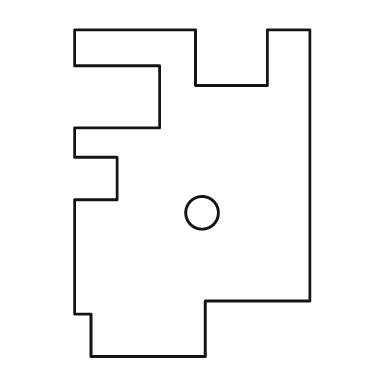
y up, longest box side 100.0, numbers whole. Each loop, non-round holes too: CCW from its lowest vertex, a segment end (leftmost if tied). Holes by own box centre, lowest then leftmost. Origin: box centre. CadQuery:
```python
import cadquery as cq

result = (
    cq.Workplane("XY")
    .moveTo(-31.0, -50.0)
    .lineTo(4.0, -50.0)
    .lineTo(4.0, -33.0)
    .lineTo(36.0, -33.0)
    .lineTo(36.0, 50.0)
    .lineTo(23.0, 50.0)
    .lineTo(23.0, 33.0)
    .lineTo(1.0, 33.0)
    .lineTo(1.0, 50.0)
    .lineTo(-36.0, 50.0)
    .lineTo(-36.0, 39.0)
    .lineTo(-10.0, 39.0)
    .lineTo(-10.0, 20.0)
    .lineTo(-36.0, 20.0)
    .lineTo(-36.0, 11.0)
    .lineTo(-23.0, 11.0)
    .lineTo(-23.0, -2.0)
    .lineTo(-36.0, -2.0)
    .lineTo(-36.0, -37.0)
    .lineTo(-31.0, -37.0)
    .close()
    .moveTo(3.0, -6.0)
    .circle(5.0)
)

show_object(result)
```